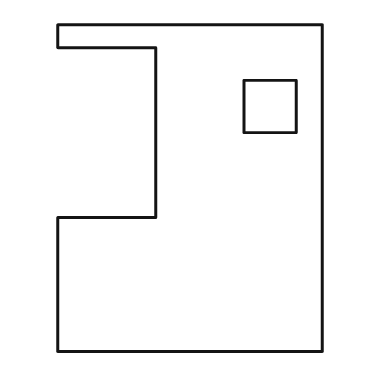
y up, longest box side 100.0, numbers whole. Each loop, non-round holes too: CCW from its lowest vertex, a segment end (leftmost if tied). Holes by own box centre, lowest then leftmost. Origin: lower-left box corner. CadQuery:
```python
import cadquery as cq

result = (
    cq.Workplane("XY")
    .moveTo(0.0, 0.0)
    .lineTo(81.0, 0.0)
    .lineTo(81.0, 100.0)
    .lineTo(0.0, 100.0)
    .lineTo(0.0, 93.0)
    .lineTo(30.0, 93.0)
    .lineTo(30.0, 41.0)
    .lineTo(0.0, 41.0)
    .close()
    .moveTo(57.0, 67.0)
    .lineTo(73.0, 67.0)
    .lineTo(73.0, 83.0)
    .lineTo(57.0, 83.0)
    .close()
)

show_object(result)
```